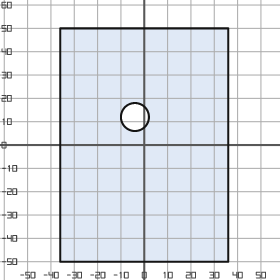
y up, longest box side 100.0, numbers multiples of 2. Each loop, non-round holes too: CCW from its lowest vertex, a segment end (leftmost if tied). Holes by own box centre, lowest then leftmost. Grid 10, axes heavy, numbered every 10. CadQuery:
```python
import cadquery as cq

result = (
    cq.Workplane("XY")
    .moveTo(-36.0, -50.0)
    .lineTo(36.0, -50.0)
    .lineTo(36.0, 50.0)
    .lineTo(-36.0, 50.0)
    .close()
    .moveTo(-4.0, 12.0)
    .circle(6.0)
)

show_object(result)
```